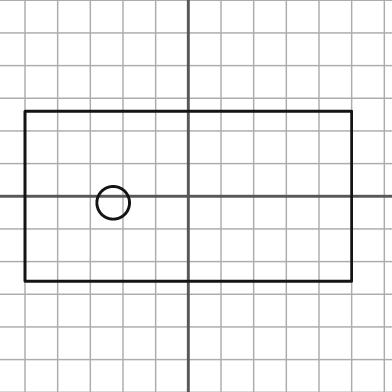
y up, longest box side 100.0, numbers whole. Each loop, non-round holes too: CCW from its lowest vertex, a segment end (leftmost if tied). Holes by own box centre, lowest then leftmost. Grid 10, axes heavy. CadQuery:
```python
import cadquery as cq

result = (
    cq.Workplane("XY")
    .moveTo(-50.0, -26.0)
    .lineTo(50.0, -26.0)
    .lineTo(50.0, 26.0)
    .lineTo(-50.0, 26.0)
    .close()
    .moveTo(-23.0, -2.0)
    .circle(5.0)
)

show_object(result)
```